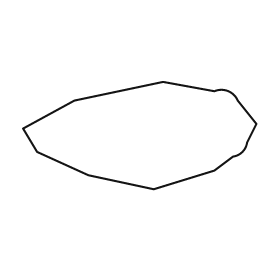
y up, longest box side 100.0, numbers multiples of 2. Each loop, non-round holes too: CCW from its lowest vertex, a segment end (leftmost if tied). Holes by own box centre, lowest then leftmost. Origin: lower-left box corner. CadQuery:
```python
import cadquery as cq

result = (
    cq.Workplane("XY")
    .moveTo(56.0, 0.0)
    .lineTo(82.0, 8.0)
    .lineTo(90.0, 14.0)
    .threePointArc((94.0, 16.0), (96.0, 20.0))
    .lineTo(100.0, 28.0)
    .lineTo(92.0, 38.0)
    .threePointArc((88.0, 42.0), (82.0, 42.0))
    .lineTo(60.0, 46.0)
    .lineTo(22.0, 38.0)
    .lineTo(0.0, 26.0)
    .lineTo(6.0, 16.0)
    .lineTo(28.0, 6.0)
    .close()
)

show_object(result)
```